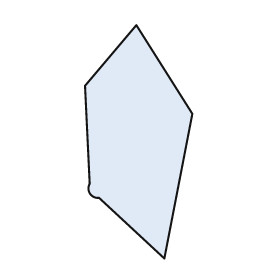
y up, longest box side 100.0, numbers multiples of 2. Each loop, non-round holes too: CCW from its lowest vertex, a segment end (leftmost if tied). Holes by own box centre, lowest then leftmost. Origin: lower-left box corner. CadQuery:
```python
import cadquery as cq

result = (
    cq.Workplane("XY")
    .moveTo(34.0, 0.0)
    .lineTo(46.0, 62.0)
    .lineTo(22.0, 100.0)
    .lineTo(0.0, 74.0)
    .lineTo(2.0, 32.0)
    .threePointArc((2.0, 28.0), (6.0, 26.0))
    .close()
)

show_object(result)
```